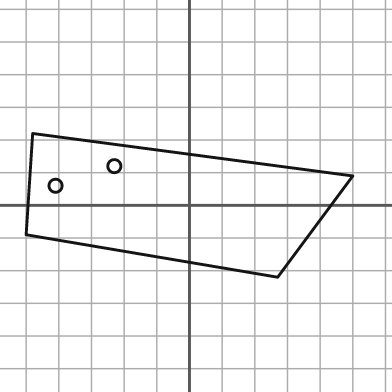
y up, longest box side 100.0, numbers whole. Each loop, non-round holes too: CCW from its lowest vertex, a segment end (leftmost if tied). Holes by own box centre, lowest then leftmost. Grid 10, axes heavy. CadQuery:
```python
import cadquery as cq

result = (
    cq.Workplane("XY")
    .moveTo(27.0, -22.0)
    .lineTo(50.0, 9.0)
    .lineTo(-48.0, 22.0)
    .lineTo(-50.0, -9.0)
    .close()
    .moveTo(-41.0, 6.0)
    .circle(2.0)
    .moveTo(-23.0, 12.0)
    .circle(2.0)
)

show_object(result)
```